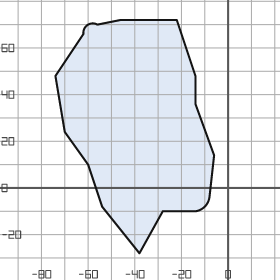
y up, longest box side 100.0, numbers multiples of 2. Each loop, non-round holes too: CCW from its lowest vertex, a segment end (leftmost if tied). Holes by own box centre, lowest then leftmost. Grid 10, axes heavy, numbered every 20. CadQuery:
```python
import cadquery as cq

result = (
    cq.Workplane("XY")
    .moveTo(-38.0, -28.0)
    .lineTo(-28.0, -10.0)
    .lineTo(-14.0, -10.0)
    .threePointArc((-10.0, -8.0), (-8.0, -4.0))
    .lineTo(-6.0, 14.0)
    .lineTo(-14.0, 36.0)
    .lineTo(-14.0, 48.0)
    .lineTo(-22.0, 72.0)
    .lineTo(-46.0, 72.0)
    .lineTo(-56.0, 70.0)
    .threePointArc((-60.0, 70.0), (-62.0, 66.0))
    .lineTo(-74.0, 48.0)
    .lineTo(-70.0, 24.0)
    .lineTo(-60.0, 10.0)
    .lineTo(-54.0, -8.0)
    .close()
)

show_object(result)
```